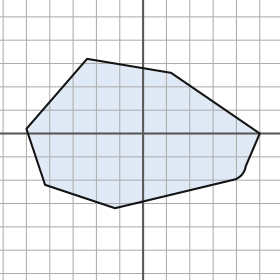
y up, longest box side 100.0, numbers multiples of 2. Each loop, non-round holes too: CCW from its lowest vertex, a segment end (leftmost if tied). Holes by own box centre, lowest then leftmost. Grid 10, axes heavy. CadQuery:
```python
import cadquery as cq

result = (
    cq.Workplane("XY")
    .moveTo(-12.0, -32.0)
    .lineTo(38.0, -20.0)
    .threePointArc((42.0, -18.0), (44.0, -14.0))
    .lineTo(50.0, 0.0)
    .lineTo(12.0, 26.0)
    .lineTo(-24.0, 32.0)
    .lineTo(-50.0, 2.0)
    .lineTo(-42.0, -22.0)
    .close()
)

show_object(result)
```